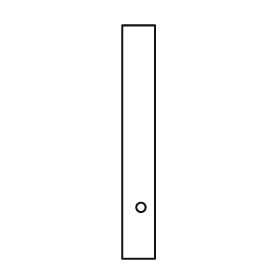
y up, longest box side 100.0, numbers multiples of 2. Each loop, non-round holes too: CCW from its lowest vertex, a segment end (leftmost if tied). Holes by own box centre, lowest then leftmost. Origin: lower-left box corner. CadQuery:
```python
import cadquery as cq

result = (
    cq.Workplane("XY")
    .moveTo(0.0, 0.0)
    .lineTo(14.0, 0.0)
    .lineTo(14.0, 100.0)
    .lineTo(0.0, 100.0)
    .close()
    .moveTo(8.0, 22.0)
    .circle(2.0)
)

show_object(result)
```